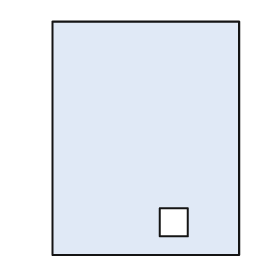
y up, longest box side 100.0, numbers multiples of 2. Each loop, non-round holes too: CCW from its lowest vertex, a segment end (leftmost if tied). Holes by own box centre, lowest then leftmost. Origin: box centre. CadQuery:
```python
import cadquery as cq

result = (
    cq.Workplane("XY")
    .moveTo(-40.0, -50.0)
    .lineTo(40.0, -50.0)
    .lineTo(40.0, 50.0)
    .lineTo(-40.0, 50.0)
    .close()
    .moveTo(6.0, -42.0)
    .lineTo(18.0, -42.0)
    .lineTo(18.0, -30.0)
    .lineTo(6.0, -30.0)
    .close()
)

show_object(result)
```